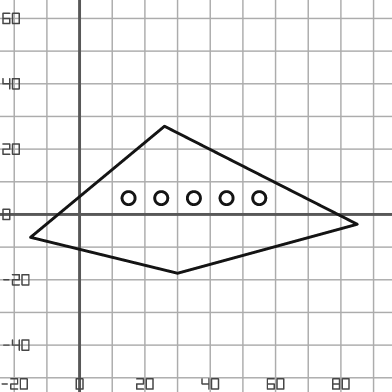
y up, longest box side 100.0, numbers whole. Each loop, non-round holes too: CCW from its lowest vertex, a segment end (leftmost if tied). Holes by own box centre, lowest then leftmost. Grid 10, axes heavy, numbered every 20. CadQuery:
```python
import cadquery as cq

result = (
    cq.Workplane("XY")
    .moveTo(30.0, -18.0)
    .lineTo(85.0, -3.0)
    .lineTo(26.0, 27.0)
    .lineTo(-15.0, -7.0)
    .close()
    .moveTo(15.0, 5.0)
    .circle(2.0)
    .moveTo(25.0, 5.0)
    .circle(2.0)
    .moveTo(35.0, 5.0)
    .circle(2.0)
    .moveTo(45.0, 5.0)
    .circle(2.0)
    .moveTo(55.0, 5.0)
    .circle(2.0)
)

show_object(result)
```